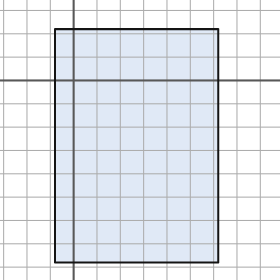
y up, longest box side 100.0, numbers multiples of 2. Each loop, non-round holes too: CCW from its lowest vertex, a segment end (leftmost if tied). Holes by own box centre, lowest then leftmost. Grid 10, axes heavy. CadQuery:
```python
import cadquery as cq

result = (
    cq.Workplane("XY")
    .moveTo(-8.0, -78.0)
    .lineTo(62.0, -78.0)
    .lineTo(62.0, 22.0)
    .lineTo(-8.0, 22.0)
    .close()
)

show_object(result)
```